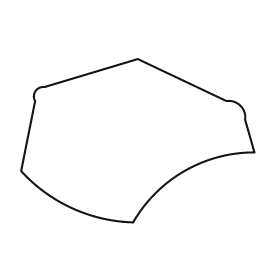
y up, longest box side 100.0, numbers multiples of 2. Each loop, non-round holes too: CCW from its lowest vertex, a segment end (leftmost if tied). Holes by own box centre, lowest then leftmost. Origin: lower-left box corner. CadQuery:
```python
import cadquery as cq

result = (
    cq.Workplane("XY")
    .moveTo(48.0, 0.0)
    .threePointArc((70.0, 22.0), (100.0, 30.0))
    .lineTo(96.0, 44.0)
    .threePointArc((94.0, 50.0), (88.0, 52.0))
    .lineTo(50.0, 70.0)
    .lineTo(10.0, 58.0)
    .threePointArc((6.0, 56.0), (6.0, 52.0))
    .lineTo(0.0, 22.0)
    .threePointArc((22.0, 6.0), (48.0, 0.0))
    .close()
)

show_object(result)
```